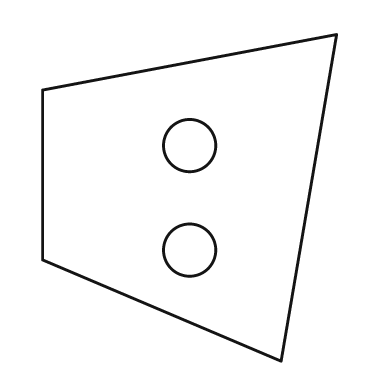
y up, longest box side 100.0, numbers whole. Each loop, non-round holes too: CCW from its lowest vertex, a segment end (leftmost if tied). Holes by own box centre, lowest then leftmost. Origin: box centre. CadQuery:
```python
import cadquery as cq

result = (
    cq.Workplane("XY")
    .moveTo(28.0, -50.0)
    .lineTo(45.0, 50.0)
    .lineTo(-45.0, 33.0)
    .lineTo(-45.0, -19.0)
    .close()
    .moveTo(0.0, -16.0)
    .circle(8.0)
    .moveTo(0.0, 16.0)
    .circle(8.0)
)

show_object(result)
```